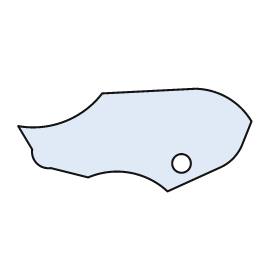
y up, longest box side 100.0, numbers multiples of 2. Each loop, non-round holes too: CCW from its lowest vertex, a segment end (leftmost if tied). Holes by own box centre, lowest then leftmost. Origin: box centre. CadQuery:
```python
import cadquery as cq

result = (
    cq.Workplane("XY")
    .moveTo(14.0, -22.0)
    .lineTo(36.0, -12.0)
    .threePointArc((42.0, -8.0), (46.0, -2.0))
    .lineTo(50.0, 8.0)
    .threePointArc((40.0, 18.0), (26.0, 22.0))
    .lineTo(-14.0, 20.0)
    .threePointArc((-30.0, 8.0), (-50.0, 6.0))
    .lineTo(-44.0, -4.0)
    .threePointArc((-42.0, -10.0), (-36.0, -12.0))
    .lineTo(-20.0, -16.0)
    .threePointArc((-2.0, -14.0), (14.0, -22.0))
    .close()
    .moveTo(20.0, -10.0)
    .circle(4.0)
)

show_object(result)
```